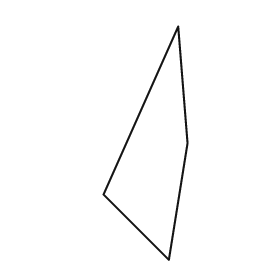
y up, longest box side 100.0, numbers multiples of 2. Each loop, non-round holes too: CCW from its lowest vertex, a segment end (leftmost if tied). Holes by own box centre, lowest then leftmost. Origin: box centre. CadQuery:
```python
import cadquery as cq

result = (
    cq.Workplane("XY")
    .moveTo(10.0, -50.0)
    .lineTo(18.0, 0.0)
    .lineTo(14.0, 50.0)
    .lineTo(-18.0, -22.0)
    .close()
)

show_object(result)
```